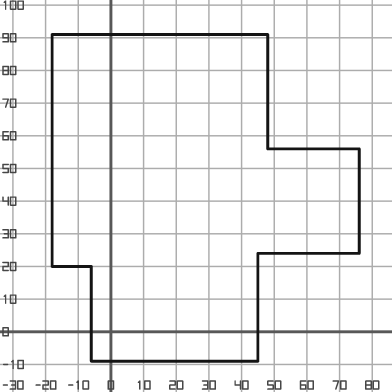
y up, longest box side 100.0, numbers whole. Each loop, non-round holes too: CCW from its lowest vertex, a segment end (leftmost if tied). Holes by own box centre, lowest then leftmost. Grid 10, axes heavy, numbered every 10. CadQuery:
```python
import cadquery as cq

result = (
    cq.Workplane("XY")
    .moveTo(-6.0, -9.0)
    .lineTo(45.0, -9.0)
    .lineTo(45.0, 24.0)
    .lineTo(76.0, 24.0)
    .lineTo(76.0, 56.0)
    .lineTo(48.0, 56.0)
    .lineTo(48.0, 91.0)
    .lineTo(-18.0, 91.0)
    .lineTo(-18.0, 20.0)
    .lineTo(-6.0, 20.0)
    .close()
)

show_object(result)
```